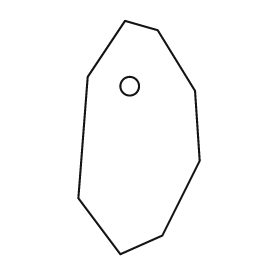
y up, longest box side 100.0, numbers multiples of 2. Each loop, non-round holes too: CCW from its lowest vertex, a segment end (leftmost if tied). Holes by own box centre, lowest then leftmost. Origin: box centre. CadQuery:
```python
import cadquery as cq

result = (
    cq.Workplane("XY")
    .moveTo(-8.0, -50.0)
    .lineTo(10.0, -42.0)
    .lineTo(26.0, -10.0)
    .lineTo(24.0, 20.0)
    .lineTo(8.0, 46.0)
    .lineTo(-6.0, 50.0)
    .lineTo(-22.0, 26.0)
    .lineTo(-26.0, -26.0)
    .close()
    .moveTo(-4.0, 22.0)
    .circle(4.0)
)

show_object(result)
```